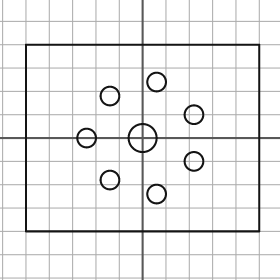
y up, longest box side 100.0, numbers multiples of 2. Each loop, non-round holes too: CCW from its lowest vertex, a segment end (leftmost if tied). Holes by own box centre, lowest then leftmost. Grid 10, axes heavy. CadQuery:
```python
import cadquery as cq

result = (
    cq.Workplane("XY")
    .moveTo(-50.0, -40.0)
    .lineTo(50.0, -40.0)
    .lineTo(50.0, 40.0)
    .lineTo(-50.0, 40.0)
    .close()
    .moveTo(6.0, -24.0)
    .circle(4.0)
    .moveTo(-14.0, -18.0)
    .circle(4.0)
    .moveTo(22.0, -10.0)
    .circle(4.0)
    .moveTo(-24.0, 0.0)
    .circle(4.0)
    .moveTo(0.0, 0.0)
    .circle(6.0)
    .moveTo(22.0, 10.0)
    .circle(4.0)
    .moveTo(-14.0, 18.0)
    .circle(4.0)
    .moveTo(6.0, 24.0)
    .circle(4.0)
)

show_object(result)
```